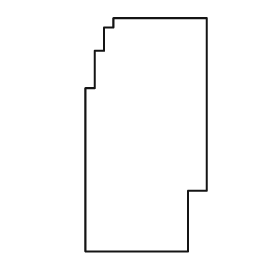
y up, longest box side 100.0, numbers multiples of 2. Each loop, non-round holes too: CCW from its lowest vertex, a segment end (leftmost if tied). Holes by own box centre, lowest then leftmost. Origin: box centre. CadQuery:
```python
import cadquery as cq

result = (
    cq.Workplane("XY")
    .moveTo(-26.0, -50.0)
    .lineTo(18.0, -50.0)
    .lineTo(18.0, -24.0)
    .lineTo(26.0, -24.0)
    .lineTo(26.0, 50.0)
    .lineTo(-14.0, 50.0)
    .lineTo(-14.0, 46.0)
    .lineTo(-18.0, 46.0)
    .lineTo(-18.0, 36.0)
    .lineTo(-22.0, 36.0)
    .lineTo(-22.0, 20.0)
    .lineTo(-26.0, 20.0)
    .close()
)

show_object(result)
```